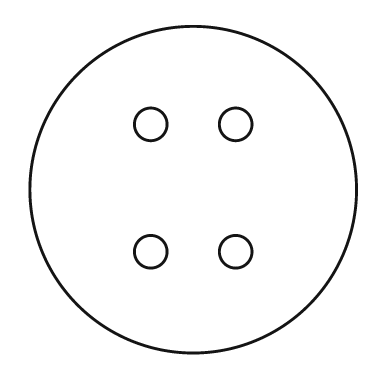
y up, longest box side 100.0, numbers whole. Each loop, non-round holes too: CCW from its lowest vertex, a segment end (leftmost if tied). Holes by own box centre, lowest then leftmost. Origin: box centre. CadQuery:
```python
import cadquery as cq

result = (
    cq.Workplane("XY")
    .moveTo(0.0, 0.0)
    .circle(50.0)
    .moveTo(-13.0, -19.0)
    .circle(5.0)
    .moveTo(13.0, -19.0)
    .circle(5.0)
    .moveTo(-13.0, 20.0)
    .circle(5.0)
    .moveTo(13.0, 20.0)
    .circle(5.0)
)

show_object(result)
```